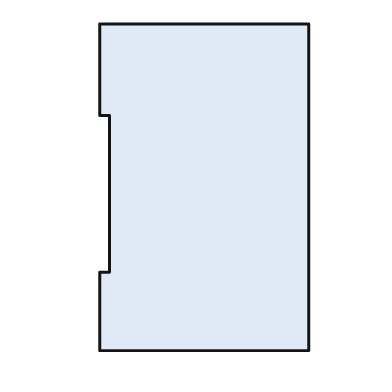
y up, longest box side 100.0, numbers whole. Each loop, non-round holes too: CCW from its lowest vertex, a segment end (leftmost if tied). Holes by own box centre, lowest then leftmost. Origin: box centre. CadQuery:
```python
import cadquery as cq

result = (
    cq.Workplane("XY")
    .moveTo(-32.0, -50.0)
    .lineTo(32.0, -50.0)
    .lineTo(32.0, 50.0)
    .lineTo(-32.0, 50.0)
    .lineTo(-32.0, 22.0)
    .lineTo(-29.0, 22.0)
    .lineTo(-29.0, -26.0)
    .lineTo(-32.0, -26.0)
    .close()
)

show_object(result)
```